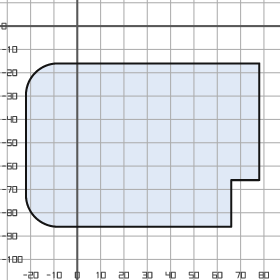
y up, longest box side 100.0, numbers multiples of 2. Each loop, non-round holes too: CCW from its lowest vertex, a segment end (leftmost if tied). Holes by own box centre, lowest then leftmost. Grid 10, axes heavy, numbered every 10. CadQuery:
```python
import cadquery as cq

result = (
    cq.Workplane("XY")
    .moveTo(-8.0, -86.0)
    .lineTo(66.0, -86.0)
    .lineTo(66.0, -66.0)
    .lineTo(78.0, -66.0)
    .lineTo(78.0, -16.0)
    .lineTo(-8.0, -16.0)
    .threePointArc((-18.0, -20.0), (-22.0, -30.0))
    .lineTo(-22.0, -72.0)
    .threePointArc((-18.0, -82.0), (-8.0, -86.0))
    .close()
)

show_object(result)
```